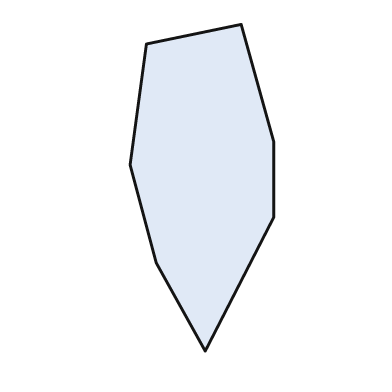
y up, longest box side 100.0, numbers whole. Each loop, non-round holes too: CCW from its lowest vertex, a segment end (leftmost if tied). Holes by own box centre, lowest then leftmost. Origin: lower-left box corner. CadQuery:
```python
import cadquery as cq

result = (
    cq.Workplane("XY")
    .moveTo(23.0, 0.0)
    .lineTo(44.0, 41.0)
    .lineTo(44.0, 64.0)
    .lineTo(34.0, 100.0)
    .lineTo(5.0, 94.0)
    .lineTo(0.0, 57.0)
    .lineTo(8.0, 27.0)
    .close()
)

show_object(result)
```